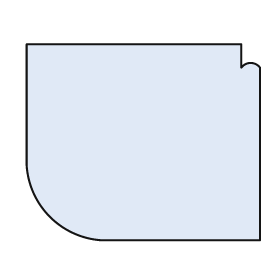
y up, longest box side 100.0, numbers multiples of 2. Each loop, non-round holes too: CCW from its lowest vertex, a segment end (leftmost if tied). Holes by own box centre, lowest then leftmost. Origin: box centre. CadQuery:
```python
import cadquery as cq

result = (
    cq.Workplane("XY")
    .moveTo(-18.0, -42.0)
    .lineTo(50.0, -42.0)
    .lineTo(50.0, 32.0)
    .threePointArc((46.0, 34.0), (42.0, 32.0))
    .lineTo(42.0, 42.0)
    .lineTo(-50.0, 42.0)
    .lineTo(-50.0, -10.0)
    .threePointArc((-40.0, -32.0), (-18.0, -42.0))
    .close()
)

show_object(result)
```